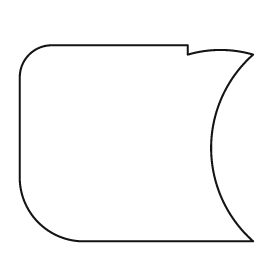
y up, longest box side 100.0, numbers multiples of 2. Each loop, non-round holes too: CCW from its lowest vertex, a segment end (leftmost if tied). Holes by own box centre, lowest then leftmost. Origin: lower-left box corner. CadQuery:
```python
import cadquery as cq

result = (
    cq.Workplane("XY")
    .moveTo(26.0, 0.0)
    .lineTo(100.0, 0.0)
    .threePointArc((82.0, 40.0), (100.0, 80.0))
    .threePointArc((86.0, 82.0), (72.0, 80.0))
    .lineTo(72.0, 84.0)
    .lineTo(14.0, 84.0)
    .threePointArc((4.0, 80.0), (0.0, 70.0))
    .lineTo(0.0, 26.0)
    .threePointArc((8.0, 8.0), (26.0, 0.0))
    .close()
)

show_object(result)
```